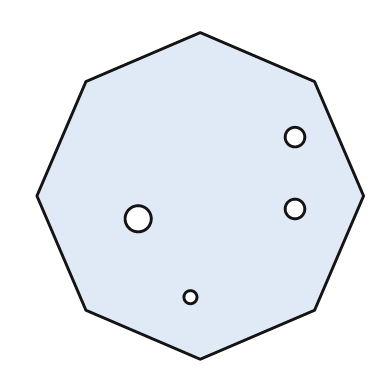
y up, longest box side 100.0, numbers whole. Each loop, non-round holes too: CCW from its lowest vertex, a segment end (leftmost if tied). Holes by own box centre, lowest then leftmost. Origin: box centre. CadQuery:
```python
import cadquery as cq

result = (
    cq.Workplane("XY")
    .moveTo(0.0, -50.0)
    .lineTo(35.0, -35.0)
    .lineTo(50.0, 0.0)
    .lineTo(35.0, 35.0)
    .lineTo(0.0, 50.0)
    .lineTo(-35.0, 35.0)
    .lineTo(-50.0, 0.0)
    .lineTo(-35.0, -35.0)
    .close()
    .moveTo(-3.0, -31.0)
    .circle(2.0)
    .moveTo(-19.0, -7.0)
    .circle(4.0)
    .moveTo(29.0, -4.0)
    .circle(3.0)
    .moveTo(29.0, 18.0)
    .circle(3.0)
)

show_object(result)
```